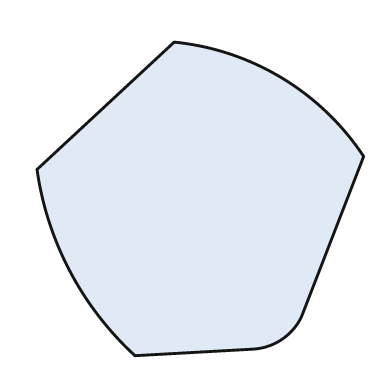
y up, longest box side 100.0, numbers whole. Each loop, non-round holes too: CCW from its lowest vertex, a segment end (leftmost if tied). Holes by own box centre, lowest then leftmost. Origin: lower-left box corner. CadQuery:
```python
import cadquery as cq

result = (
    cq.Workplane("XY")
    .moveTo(30.0, 0.0)
    .lineTo(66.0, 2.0)
    .threePointArc((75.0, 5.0), (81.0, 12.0))
    .lineTo(100.0, 61.0)
    .threePointArc((75.0, 85.0), (42.0, 96.0))
    .lineTo(0.0, 57.0)
    .threePointArc((10.0, 26.0), (30.0, 0.0))
    .close()
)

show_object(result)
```